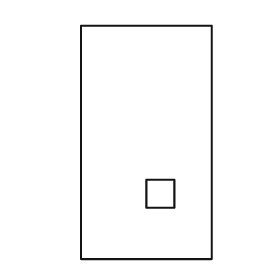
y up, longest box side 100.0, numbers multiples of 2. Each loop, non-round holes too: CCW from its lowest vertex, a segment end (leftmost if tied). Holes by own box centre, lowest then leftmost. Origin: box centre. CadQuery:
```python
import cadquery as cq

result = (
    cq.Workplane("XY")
    .moveTo(-28.0, -50.0)
    .lineTo(28.0, -50.0)
    .lineTo(28.0, 50.0)
    .lineTo(-28.0, 50.0)
    .close()
    .moveTo(0.0, -28.0)
    .lineTo(12.0, -28.0)
    .lineTo(12.0, -16.0)
    .lineTo(0.0, -16.0)
    .close()
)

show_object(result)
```